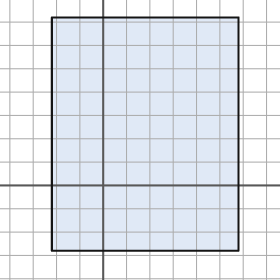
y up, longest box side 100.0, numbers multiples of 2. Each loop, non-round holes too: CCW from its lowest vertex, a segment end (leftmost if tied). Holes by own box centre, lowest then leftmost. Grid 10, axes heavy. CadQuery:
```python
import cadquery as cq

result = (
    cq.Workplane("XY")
    .moveTo(-22.0, -28.0)
    .lineTo(58.0, -28.0)
    .lineTo(58.0, 72.0)
    .lineTo(-22.0, 72.0)
    .close()
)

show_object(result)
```